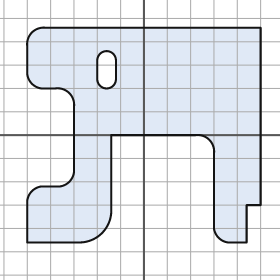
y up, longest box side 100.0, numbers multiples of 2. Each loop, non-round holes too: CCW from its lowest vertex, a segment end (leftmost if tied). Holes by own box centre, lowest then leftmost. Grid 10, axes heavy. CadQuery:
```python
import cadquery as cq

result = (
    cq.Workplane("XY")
    .moveTo(-50.0, -46.0)
    .lineTo(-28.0, -46.0)
    .threePointArc((-18.0, -42.0), (-14.0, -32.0))
    .lineTo(-14.0, 0.0)
    .lineTo(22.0, 0.0)
    .threePointArc((28.0, -2.0), (30.0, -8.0))
    .lineTo(30.0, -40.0)
    .threePointArc((32.0, -44.0), (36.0, -46.0))
    .lineTo(44.0, -46.0)
    .lineTo(44.0, -30.0)
    .lineTo(50.0, -30.0)
    .lineTo(50.0, 46.0)
    .lineTo(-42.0, 46.0)
    .threePointArc((-48.0, 44.0), (-50.0, 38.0))
    .lineTo(-50.0, 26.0)
    .threePointArc((-48.0, 22.0), (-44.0, 20.0))
    .lineTo(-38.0, 20.0)
    .threePointArc((-32.0, 18.0), (-30.0, 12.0))
    .lineTo(-30.0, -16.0)
    .threePointArc((-32.0, -20.0), (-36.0, -22.0))
    .lineTo(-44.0, -22.0)
    .threePointArc((-48.0, -24.0), (-50.0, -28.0))
    .close()
    .moveTo(-20.0, 24.0)
    .threePointArc((-16.0, 20.0), (-12.0, 24.0))
    .lineTo(-12.0, 32.0)
    .threePointArc((-16.0, 36.0), (-20.0, 32.0))
    .close()
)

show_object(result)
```